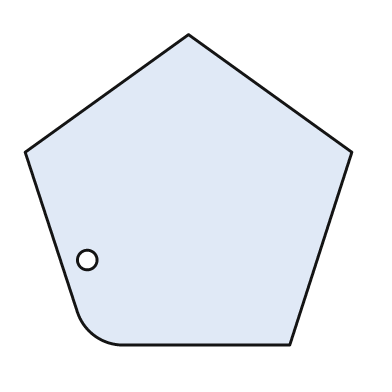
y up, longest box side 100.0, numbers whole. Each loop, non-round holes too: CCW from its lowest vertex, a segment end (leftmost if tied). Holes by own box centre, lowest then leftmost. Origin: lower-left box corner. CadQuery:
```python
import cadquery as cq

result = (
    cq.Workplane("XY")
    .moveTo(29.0, 0.0)
    .lineTo(81.0, 0.0)
    .lineTo(100.0, 59.0)
    .lineTo(50.0, 95.0)
    .lineTo(0.0, 59.0)
    .lineTo(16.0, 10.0)
    .threePointArc((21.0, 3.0), (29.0, 0.0))
    .close()
    .moveTo(19.0, 26.0)
    .circle(3.0)
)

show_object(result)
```